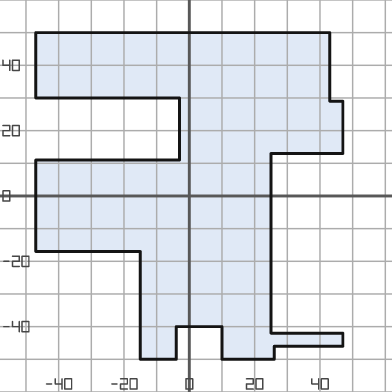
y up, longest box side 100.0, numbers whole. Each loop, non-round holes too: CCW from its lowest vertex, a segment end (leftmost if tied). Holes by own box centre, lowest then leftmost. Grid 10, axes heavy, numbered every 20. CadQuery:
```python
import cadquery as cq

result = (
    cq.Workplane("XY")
    .moveTo(-15.0, -50.0)
    .lineTo(-4.0, -50.0)
    .lineTo(-4.0, -40.0)
    .lineTo(10.0, -40.0)
    .lineTo(10.0, -50.0)
    .lineTo(26.0, -50.0)
    .lineTo(26.0, -46.0)
    .lineTo(47.0, -46.0)
    .lineTo(47.0, -42.0)
    .lineTo(25.0, -42.0)
    .lineTo(25.0, 13.0)
    .lineTo(47.0, 13.0)
    .lineTo(47.0, 29.0)
    .lineTo(43.0, 29.0)
    .lineTo(43.0, 50.0)
    .lineTo(-47.0, 50.0)
    .lineTo(-47.0, 30.0)
    .lineTo(-3.0, 30.0)
    .lineTo(-3.0, 11.0)
    .lineTo(-47.0, 11.0)
    .lineTo(-47.0, -17.0)
    .lineTo(-15.0, -17.0)
    .close()
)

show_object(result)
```